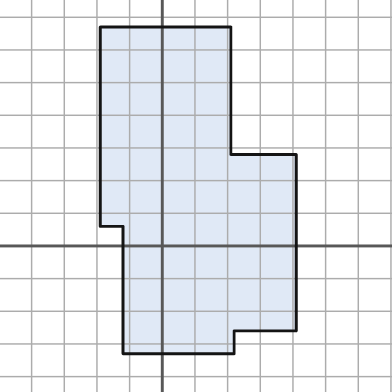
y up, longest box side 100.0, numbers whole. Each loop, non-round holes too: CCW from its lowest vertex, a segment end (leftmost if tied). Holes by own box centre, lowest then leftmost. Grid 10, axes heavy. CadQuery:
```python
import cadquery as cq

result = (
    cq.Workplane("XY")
    .moveTo(-12.0, -33.0)
    .lineTo(22.0, -33.0)
    .lineTo(22.0, -26.0)
    .lineTo(41.0, -26.0)
    .lineTo(41.0, 28.0)
    .lineTo(21.0, 28.0)
    .lineTo(21.0, 67.0)
    .lineTo(-19.0, 67.0)
    .lineTo(-19.0, 6.0)
    .lineTo(-12.0, 6.0)
    .close()
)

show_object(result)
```